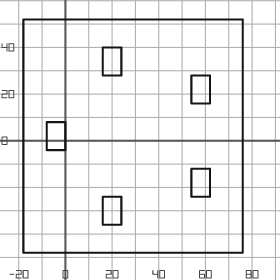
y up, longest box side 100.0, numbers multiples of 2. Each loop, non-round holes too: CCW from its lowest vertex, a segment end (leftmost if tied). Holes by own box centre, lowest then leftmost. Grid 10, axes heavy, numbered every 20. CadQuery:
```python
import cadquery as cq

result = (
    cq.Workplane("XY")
    .moveTo(-18.0, -48.0)
    .lineTo(76.0, -48.0)
    .lineTo(76.0, 52.0)
    .lineTo(-18.0, 52.0)
    .close()
    .moveTo(16.0, -36.0)
    .lineTo(24.0, -36.0)
    .lineTo(24.0, -24.0)
    .lineTo(16.0, -24.0)
    .close()
    .moveTo(54.0, -24.0)
    .lineTo(62.0, -24.0)
    .lineTo(62.0, -12.0)
    .lineTo(54.0, -12.0)
    .close()
    .moveTo(-8.0, -4.0)
    .lineTo(0.0, -4.0)
    .lineTo(0.0, 8.0)
    .lineTo(-8.0, 8.0)
    .close()
    .moveTo(54.0, 16.0)
    .lineTo(62.0, 16.0)
    .lineTo(62.0, 28.0)
    .lineTo(54.0, 28.0)
    .close()
    .moveTo(16.0, 28.0)
    .lineTo(24.0, 28.0)
    .lineTo(24.0, 40.0)
    .lineTo(16.0, 40.0)
    .close()
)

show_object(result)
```